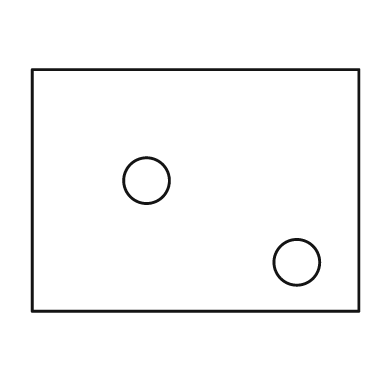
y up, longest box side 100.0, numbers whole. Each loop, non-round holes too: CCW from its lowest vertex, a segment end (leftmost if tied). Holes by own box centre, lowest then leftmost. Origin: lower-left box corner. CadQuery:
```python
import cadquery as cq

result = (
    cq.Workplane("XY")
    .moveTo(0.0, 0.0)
    .lineTo(100.0, 0.0)
    .lineTo(100.0, 74.0)
    .lineTo(0.0, 74.0)
    .close()
    .moveTo(81.0, 15.0)
    .circle(7.0)
    .moveTo(35.0, 40.0)
    .circle(7.0)
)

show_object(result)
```